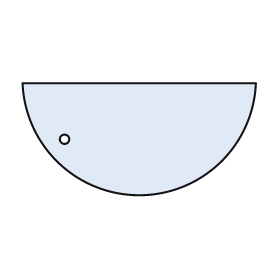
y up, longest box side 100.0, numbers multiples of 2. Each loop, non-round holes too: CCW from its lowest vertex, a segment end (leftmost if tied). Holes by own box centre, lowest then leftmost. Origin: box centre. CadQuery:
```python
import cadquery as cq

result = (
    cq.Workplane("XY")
    .moveTo(-50.0, 24.0)
    .threePointArc((0.0, -24.0), (50.0, 24.0))
    .close()
    .moveTo(-32.0, 0.0)
    .circle(2.0)
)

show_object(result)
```